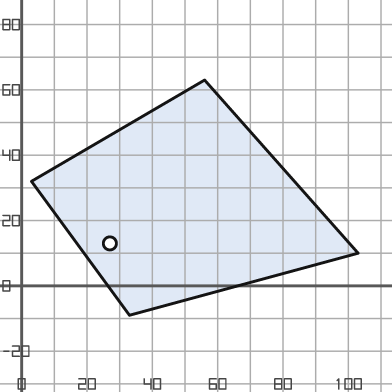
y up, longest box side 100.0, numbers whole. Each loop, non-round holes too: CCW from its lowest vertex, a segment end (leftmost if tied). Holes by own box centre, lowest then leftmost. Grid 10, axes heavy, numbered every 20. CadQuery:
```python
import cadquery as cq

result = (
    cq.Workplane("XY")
    .moveTo(33.0, -9.0)
    .lineTo(103.0, 10.0)
    .lineTo(56.0, 63.0)
    .lineTo(3.0, 32.0)
    .close()
    .moveTo(27.0, 13.0)
    .circle(2.0)
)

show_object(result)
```